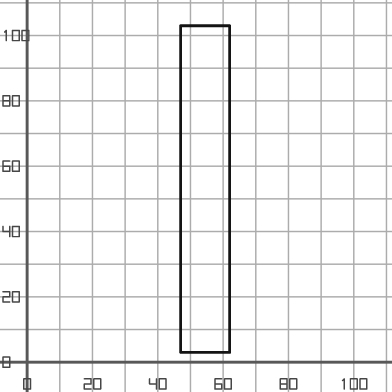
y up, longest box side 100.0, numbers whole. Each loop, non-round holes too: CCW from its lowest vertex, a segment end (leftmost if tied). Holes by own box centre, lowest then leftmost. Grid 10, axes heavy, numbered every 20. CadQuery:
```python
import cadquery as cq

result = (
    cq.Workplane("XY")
    .moveTo(47.0, 3.0)
    .lineTo(62.0, 3.0)
    .lineTo(62.0, 103.0)
    .lineTo(47.0, 103.0)
    .close()
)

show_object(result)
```